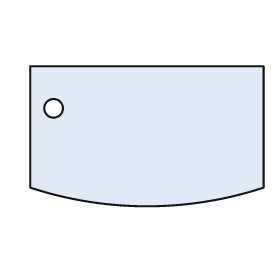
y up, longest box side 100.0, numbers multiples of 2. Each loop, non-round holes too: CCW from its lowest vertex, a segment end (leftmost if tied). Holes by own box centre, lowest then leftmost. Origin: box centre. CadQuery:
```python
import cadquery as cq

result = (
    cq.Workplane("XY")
    .moveTo(-50.0, -22.0)
    .threePointArc((0.0, -30.0), (50.0, -22.0))
    .lineTo(50.0, 30.0)
    .lineTo(-50.0, 30.0)
    .close()
    .moveTo(-40.0, 12.0)
    .circle(4.0)
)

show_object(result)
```